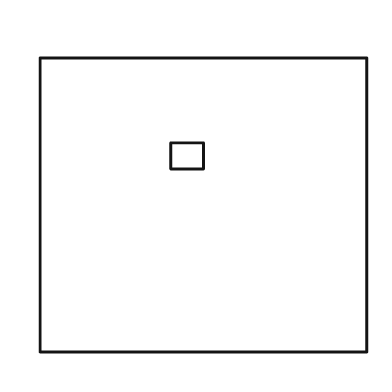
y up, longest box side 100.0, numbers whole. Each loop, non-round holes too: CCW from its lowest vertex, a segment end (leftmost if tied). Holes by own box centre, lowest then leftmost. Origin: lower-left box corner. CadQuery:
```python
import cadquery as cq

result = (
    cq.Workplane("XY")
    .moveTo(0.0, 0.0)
    .lineTo(100.0, 0.0)
    .lineTo(100.0, 90.0)
    .lineTo(0.0, 90.0)
    .close()
    .moveTo(40.0, 56.0)
    .lineTo(50.0, 56.0)
    .lineTo(50.0, 64.0)
    .lineTo(40.0, 64.0)
    .close()
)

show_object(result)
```